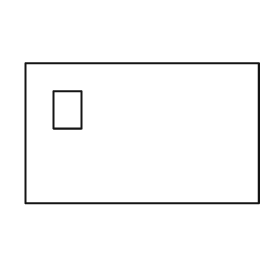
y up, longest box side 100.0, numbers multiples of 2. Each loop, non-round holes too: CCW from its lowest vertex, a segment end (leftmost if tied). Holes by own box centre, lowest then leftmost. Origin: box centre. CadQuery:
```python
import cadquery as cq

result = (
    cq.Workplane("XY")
    .moveTo(-50.0, -30.0)
    .lineTo(50.0, -30.0)
    .lineTo(50.0, 30.0)
    .lineTo(-50.0, 30.0)
    .close()
    .moveTo(-38.0, 2.0)
    .lineTo(-26.0, 2.0)
    .lineTo(-26.0, 18.0)
    .lineTo(-38.0, 18.0)
    .close()
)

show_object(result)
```